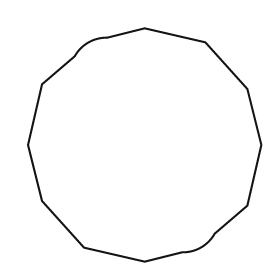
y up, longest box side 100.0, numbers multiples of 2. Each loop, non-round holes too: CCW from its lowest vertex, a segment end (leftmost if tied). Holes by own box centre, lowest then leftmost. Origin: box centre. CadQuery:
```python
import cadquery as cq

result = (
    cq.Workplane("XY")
    .moveTo(0.0, -50.0)
    .lineTo(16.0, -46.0)
    .threePointArc((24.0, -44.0), (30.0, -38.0))
    .lineTo(44.0, -26.0)
    .lineTo(50.0, 0.0)
    .lineTo(44.0, 24.0)
    .lineTo(26.0, 44.0)
    .lineTo(0.0, 50.0)
    .lineTo(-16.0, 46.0)
    .threePointArc((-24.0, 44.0), (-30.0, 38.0))
    .lineTo(-44.0, 26.0)
    .lineTo(-50.0, 0.0)
    .lineTo(-44.0, -24.0)
    .lineTo(-26.0, -44.0)
    .close()
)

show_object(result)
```